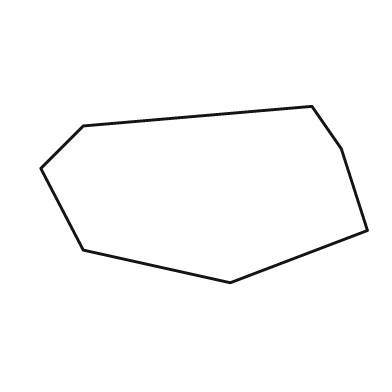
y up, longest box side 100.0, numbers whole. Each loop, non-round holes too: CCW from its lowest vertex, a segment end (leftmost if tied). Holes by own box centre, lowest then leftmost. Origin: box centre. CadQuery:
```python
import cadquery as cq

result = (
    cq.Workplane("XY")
    .moveTo(8.0, -27.0)
    .lineTo(50.0, -11.0)
    .lineTo(42.0, 14.0)
    .lineTo(33.0, 27.0)
    .lineTo(-37.0, 21.0)
    .lineTo(-50.0, 8.0)
    .lineTo(-37.0, -17.0)
    .close()
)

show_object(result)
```